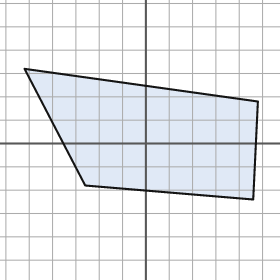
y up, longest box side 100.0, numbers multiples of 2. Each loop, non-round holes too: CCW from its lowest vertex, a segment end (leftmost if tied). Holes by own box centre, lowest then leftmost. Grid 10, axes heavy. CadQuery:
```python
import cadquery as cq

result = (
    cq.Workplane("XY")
    .moveTo(46.0, -24.0)
    .lineTo(48.0, 18.0)
    .lineTo(-52.0, 32.0)
    .lineTo(-26.0, -18.0)
    .close()
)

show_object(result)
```